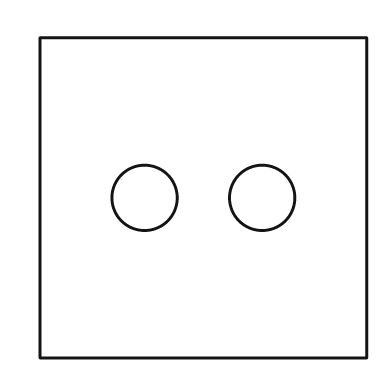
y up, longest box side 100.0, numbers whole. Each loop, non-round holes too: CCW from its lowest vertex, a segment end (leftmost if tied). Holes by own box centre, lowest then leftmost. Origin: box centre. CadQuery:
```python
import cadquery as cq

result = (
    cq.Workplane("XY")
    .moveTo(-50.0, -49.0)
    .lineTo(50.0, -49.0)
    .lineTo(50.0, 49.0)
    .lineTo(-50.0, 49.0)
    .close()
    .moveTo(-18.0, 0.0)
    .circle(10.0)
    .moveTo(18.0, 0.0)
    .circle(10.0)
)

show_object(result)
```